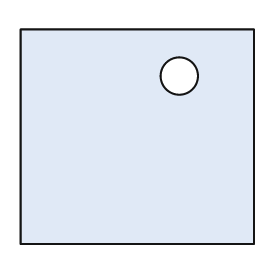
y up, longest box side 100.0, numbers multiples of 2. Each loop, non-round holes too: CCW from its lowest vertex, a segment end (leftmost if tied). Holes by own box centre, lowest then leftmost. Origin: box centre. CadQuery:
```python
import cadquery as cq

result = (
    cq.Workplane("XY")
    .moveTo(-50.0, -46.0)
    .lineTo(50.0, -46.0)
    .lineTo(50.0, 46.0)
    .lineTo(-50.0, 46.0)
    .close()
    .moveTo(18.0, 26.0)
    .circle(8.0)
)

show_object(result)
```